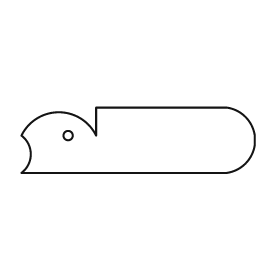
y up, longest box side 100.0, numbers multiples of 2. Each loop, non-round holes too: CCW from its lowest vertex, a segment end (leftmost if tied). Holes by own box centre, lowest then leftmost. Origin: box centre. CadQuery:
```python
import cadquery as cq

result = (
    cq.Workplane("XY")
    .moveTo(-50.0, -14.0)
    .lineTo(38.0, -14.0)
    .threePointArc((46.0, -10.0), (50.0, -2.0))
    .lineTo(50.0, 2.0)
    .threePointArc((46.0, 10.0), (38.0, 14.0))
    .lineTo(-18.0, 14.0)
    .lineTo(-18.0, 2.0)
    .threePointArc((-34.0, 12.0), (-50.0, 2.0))
    .threePointArc((-46.0, -6.0), (-50.0, -14.0))
    .close()
    .moveTo(-30.0, 2.0)
    .circle(2.0)
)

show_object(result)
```